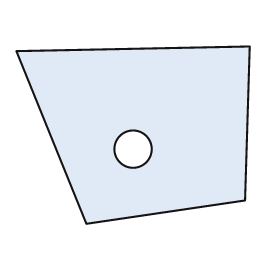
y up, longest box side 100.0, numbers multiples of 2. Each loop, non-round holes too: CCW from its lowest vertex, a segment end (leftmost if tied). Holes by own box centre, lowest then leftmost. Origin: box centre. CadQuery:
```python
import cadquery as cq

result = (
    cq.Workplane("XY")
    .moveTo(-20.0, -38.0)
    .lineTo(48.0, -28.0)
    .lineTo(50.0, 38.0)
    .lineTo(-50.0, 36.0)
    .close()
    .moveTo(0.0, -6.0)
    .circle(8.0)
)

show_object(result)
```